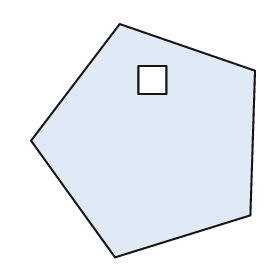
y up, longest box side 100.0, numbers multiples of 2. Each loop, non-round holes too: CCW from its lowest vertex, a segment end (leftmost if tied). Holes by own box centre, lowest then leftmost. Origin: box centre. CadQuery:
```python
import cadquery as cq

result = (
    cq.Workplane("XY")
    .moveTo(-12.0, -50.0)
    .lineTo(46.0, -32.0)
    .lineTo(48.0, 30.0)
    .lineTo(-10.0, 50.0)
    .lineTo(-48.0, 0.0)
    .close()
    .moveTo(-2.0, 20.0)
    .lineTo(10.0, 20.0)
    .lineTo(10.0, 32.0)
    .lineTo(-2.0, 32.0)
    .close()
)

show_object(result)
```